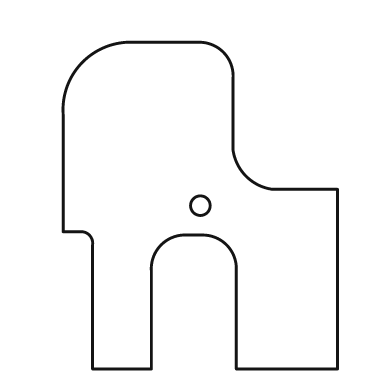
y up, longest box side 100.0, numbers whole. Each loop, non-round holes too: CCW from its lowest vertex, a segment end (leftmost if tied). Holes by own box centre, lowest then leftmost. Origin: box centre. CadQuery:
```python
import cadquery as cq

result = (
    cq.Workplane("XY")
    .moveTo(-33.0, -50.0)
    .lineTo(-15.0, -50.0)
    .lineTo(-15.0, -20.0)
    .threePointArc((-12.0, -12.0), (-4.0, -9.0))
    .lineTo(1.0, -9.0)
    .threePointArc((8.0, -12.0), (11.0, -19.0))
    .lineTo(11.0, -50.0)
    .lineTo(42.0, -50.0)
    .lineTo(42.0, 5.0)
    .lineTo(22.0, 5.0)
    .threePointArc((14.0, 9.0), (10.0, 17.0))
    .lineTo(10.0, 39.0)
    .threePointArc((7.0, 47.0), (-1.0, 50.0))
    .lineTo(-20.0, 50.0)
    .threePointArc((-36.0, 44.0), (-42.0, 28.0))
    .lineTo(-42.0, -8.0)
    .lineTo(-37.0, -8.0)
    .threePointArc((-34.0, -9.0), (-33.0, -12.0))
    .close()
    .moveTo(0.0, 0.0)
    .circle(3.0)
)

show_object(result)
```